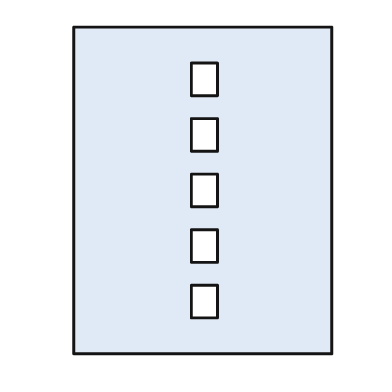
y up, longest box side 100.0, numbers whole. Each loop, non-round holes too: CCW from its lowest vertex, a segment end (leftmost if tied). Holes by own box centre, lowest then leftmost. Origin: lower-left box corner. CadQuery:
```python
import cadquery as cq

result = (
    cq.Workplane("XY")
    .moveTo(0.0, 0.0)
    .lineTo(79.0, 0.0)
    .lineTo(79.0, 100.0)
    .lineTo(0.0, 100.0)
    .close()
    .moveTo(36.0, 11.0)
    .lineTo(44.0, 11.0)
    .lineTo(44.0, 21.0)
    .lineTo(36.0, 21.0)
    .close()
    .moveTo(36.0, 28.0)
    .lineTo(44.0, 28.0)
    .lineTo(44.0, 38.0)
    .lineTo(36.0, 38.0)
    .close()
    .moveTo(36.0, 45.0)
    .lineTo(44.0, 45.0)
    .lineTo(44.0, 55.0)
    .lineTo(36.0, 55.0)
    .close()
    .moveTo(36.0, 62.0)
    .lineTo(44.0, 62.0)
    .lineTo(44.0, 72.0)
    .lineTo(36.0, 72.0)
    .close()
    .moveTo(36.0, 79.0)
    .lineTo(44.0, 79.0)
    .lineTo(44.0, 89.0)
    .lineTo(36.0, 89.0)
    .close()
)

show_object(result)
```